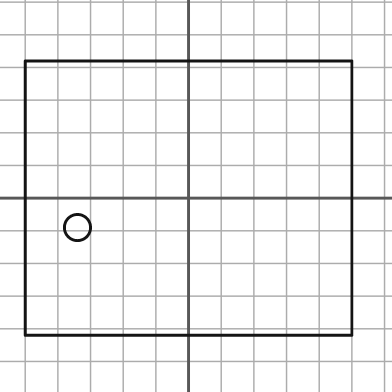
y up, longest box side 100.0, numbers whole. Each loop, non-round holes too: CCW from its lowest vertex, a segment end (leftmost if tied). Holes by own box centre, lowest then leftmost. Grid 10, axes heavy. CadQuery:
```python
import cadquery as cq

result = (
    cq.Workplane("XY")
    .moveTo(-50.0, -42.0)
    .lineTo(50.0, -42.0)
    .lineTo(50.0, 42.0)
    .lineTo(-50.0, 42.0)
    .close()
    .moveTo(-34.0, -9.0)
    .circle(4.0)
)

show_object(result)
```